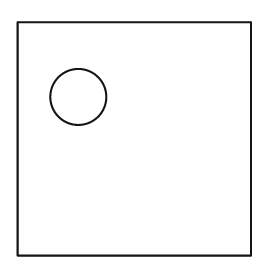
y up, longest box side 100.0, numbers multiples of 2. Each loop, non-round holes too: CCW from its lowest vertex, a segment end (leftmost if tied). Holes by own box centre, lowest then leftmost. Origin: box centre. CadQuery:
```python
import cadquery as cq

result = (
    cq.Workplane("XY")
    .moveTo(-50.0, -50.0)
    .lineTo(50.0, -50.0)
    .lineTo(50.0, 50.0)
    .lineTo(-50.0, 50.0)
    .close()
    .moveTo(-24.0, 18.0)
    .circle(12.0)
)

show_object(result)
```